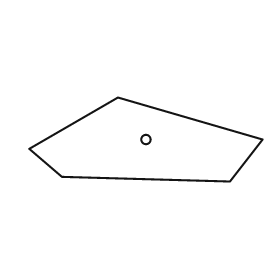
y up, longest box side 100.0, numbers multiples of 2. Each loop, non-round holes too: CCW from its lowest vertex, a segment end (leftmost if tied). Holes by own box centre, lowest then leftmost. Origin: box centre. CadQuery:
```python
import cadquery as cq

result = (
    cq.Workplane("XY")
    .moveTo(36.0, -18.0)
    .lineTo(50.0, 0.0)
    .lineTo(-12.0, 18.0)
    .lineTo(-50.0, -4.0)
    .lineTo(-36.0, -16.0)
    .close()
    .moveTo(0.0, 0.0)
    .circle(2.0)
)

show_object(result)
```